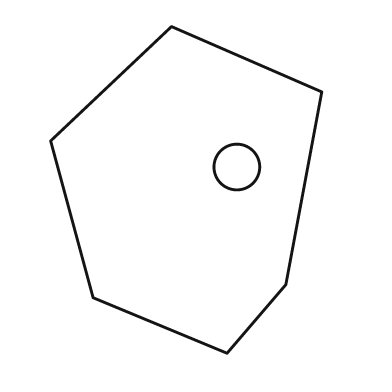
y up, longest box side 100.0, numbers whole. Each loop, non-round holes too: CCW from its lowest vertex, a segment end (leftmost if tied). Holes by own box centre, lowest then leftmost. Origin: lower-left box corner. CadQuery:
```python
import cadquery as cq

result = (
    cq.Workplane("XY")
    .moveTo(54.0, 0.0)
    .lineTo(72.0, 21.0)
    .lineTo(83.0, 80.0)
    .lineTo(37.0, 100.0)
    .lineTo(0.0, 65.0)
    .lineTo(13.0, 17.0)
    .close()
    .moveTo(57.0, 57.0)
    .circle(7.0)
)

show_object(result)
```